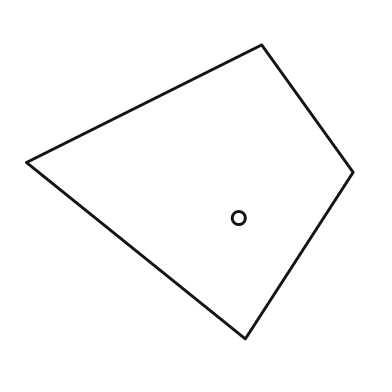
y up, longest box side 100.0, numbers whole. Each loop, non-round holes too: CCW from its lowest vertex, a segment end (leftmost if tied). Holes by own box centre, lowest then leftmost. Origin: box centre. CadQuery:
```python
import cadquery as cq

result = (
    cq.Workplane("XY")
    .moveTo(17.0, -45.0)
    .lineTo(50.0, 6.0)
    .lineTo(22.0, 45.0)
    .lineTo(-50.0, 9.0)
    .close()
    .moveTo(15.0, -8.0)
    .circle(2.0)
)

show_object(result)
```